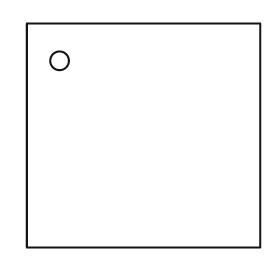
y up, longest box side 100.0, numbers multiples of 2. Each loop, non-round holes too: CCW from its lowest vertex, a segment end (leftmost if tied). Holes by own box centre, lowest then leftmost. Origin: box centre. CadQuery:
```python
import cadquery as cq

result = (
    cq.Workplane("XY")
    .moveTo(-50.0, -48.0)
    .lineTo(50.0, -48.0)
    .lineTo(50.0, 48.0)
    .lineTo(-50.0, 48.0)
    .close()
    .moveTo(-36.0, 32.0)
    .circle(4.0)
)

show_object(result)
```